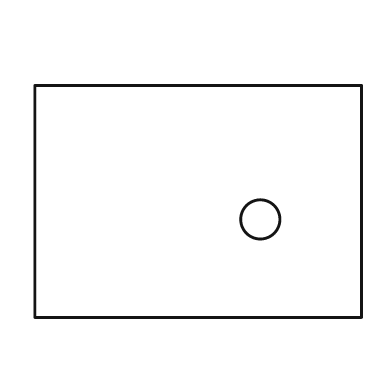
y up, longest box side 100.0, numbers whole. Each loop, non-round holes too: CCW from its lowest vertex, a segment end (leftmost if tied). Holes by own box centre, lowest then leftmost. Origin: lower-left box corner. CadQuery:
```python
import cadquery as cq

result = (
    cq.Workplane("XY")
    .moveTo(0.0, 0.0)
    .lineTo(100.0, 0.0)
    .lineTo(100.0, 71.0)
    .lineTo(0.0, 71.0)
    .close()
    .moveTo(69.0, 30.0)
    .circle(6.0)
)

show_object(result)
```